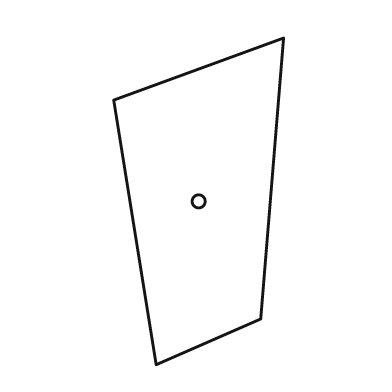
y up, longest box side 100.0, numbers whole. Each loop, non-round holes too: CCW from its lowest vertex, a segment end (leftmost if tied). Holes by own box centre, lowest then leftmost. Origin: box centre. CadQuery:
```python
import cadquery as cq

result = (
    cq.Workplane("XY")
    .moveTo(-13.0, -50.0)
    .lineTo(19.0, -36.0)
    .lineTo(26.0, 50.0)
    .lineTo(-26.0, 31.0)
    .close()
    .moveTo(0.0, 0.0)
    .circle(2.0)
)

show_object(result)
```